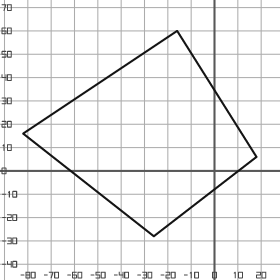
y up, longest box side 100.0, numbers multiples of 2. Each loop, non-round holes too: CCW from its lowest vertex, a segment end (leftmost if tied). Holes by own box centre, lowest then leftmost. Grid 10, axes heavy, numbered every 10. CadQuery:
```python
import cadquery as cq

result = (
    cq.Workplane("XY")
    .moveTo(-26.0, -28.0)
    .lineTo(18.0, 6.0)
    .lineTo(-16.0, 60.0)
    .lineTo(-82.0, 16.0)
    .close()
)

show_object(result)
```